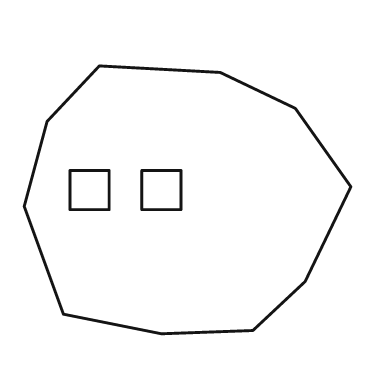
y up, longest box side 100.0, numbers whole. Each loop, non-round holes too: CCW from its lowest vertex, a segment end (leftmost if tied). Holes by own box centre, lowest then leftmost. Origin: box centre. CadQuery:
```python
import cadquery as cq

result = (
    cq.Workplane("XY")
    .moveTo(-8.0, -41.0)
    .lineTo(20.0, -40.0)
    .lineTo(36.0, -25.0)
    .lineTo(50.0, 4.0)
    .lineTo(33.0, 28.0)
    .lineTo(10.0, 39.0)
    .lineTo(-27.0, 41.0)
    .lineTo(-43.0, 24.0)
    .lineTo(-50.0, -2.0)
    .lineTo(-38.0, -35.0)
    .close()
    .moveTo(-36.0, -3.0)
    .lineTo(-24.0, -3.0)
    .lineTo(-24.0, 9.0)
    .lineTo(-36.0, 9.0)
    .close()
    .moveTo(-14.0, -3.0)
    .lineTo(-2.0, -3.0)
    .lineTo(-2.0, 9.0)
    .lineTo(-14.0, 9.0)
    .close()
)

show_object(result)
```